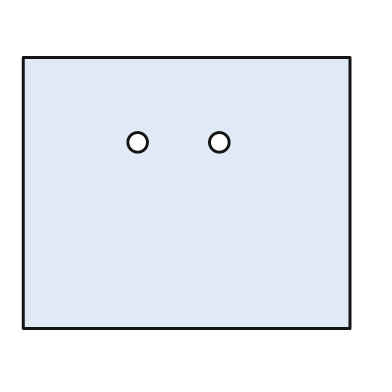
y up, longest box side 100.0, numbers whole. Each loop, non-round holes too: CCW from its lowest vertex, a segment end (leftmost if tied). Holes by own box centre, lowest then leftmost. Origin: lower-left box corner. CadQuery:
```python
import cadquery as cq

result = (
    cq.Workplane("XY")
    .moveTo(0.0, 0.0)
    .lineTo(100.0, 0.0)
    .lineTo(100.0, 83.0)
    .lineTo(0.0, 83.0)
    .close()
    .moveTo(35.0, 57.0)
    .circle(3.0)
    .moveTo(60.0, 57.0)
    .circle(3.0)
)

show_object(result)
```